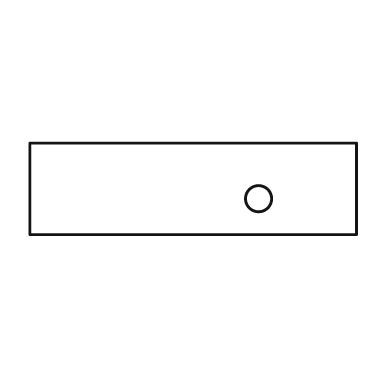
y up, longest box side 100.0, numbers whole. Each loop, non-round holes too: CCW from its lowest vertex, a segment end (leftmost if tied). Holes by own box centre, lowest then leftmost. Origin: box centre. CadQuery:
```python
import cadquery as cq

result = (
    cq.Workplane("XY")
    .moveTo(-50.0, -14.0)
    .lineTo(50.0, -14.0)
    .lineTo(50.0, 14.0)
    .lineTo(-50.0, 14.0)
    .close()
    .moveTo(20.0, -3.0)
    .circle(4.0)
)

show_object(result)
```